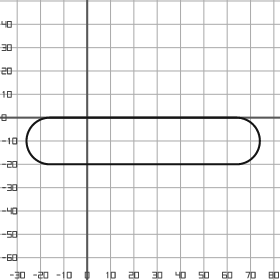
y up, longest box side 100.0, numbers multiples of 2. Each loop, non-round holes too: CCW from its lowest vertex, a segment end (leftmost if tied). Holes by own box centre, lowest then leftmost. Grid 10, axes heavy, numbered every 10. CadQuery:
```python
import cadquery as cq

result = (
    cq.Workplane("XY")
    .moveTo(-16.0, -20.0)
    .lineTo(64.0, -20.0)
    .threePointArc((74.0, -10.0), (64.0, 0.0))
    .lineTo(-16.0, 0.0)
    .threePointArc((-26.0, -10.0), (-16.0, -20.0))
    .close()
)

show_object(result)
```